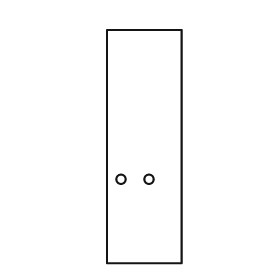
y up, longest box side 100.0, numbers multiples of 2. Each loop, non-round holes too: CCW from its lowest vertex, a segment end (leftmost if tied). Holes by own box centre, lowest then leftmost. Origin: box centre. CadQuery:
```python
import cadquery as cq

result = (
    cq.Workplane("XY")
    .moveTo(-16.0, -50.0)
    .lineTo(16.0, -50.0)
    .lineTo(16.0, 50.0)
    .lineTo(-16.0, 50.0)
    .close()
    .moveTo(-10.0, -14.0)
    .circle(2.0)
    .moveTo(2.0, -14.0)
    .circle(2.0)
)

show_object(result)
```